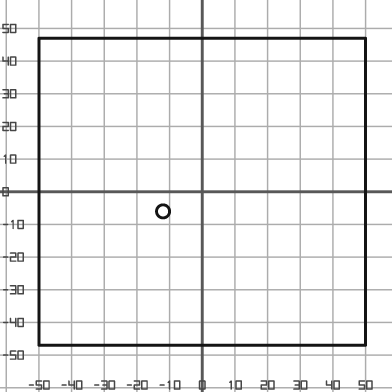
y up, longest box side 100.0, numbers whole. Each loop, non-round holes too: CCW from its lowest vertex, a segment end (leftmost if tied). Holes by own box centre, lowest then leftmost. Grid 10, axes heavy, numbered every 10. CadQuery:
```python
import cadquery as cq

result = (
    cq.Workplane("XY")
    .moveTo(-50.0, -47.0)
    .lineTo(50.0, -47.0)
    .lineTo(50.0, 47.0)
    .lineTo(-50.0, 47.0)
    .close()
    .moveTo(-12.0, -6.0)
    .circle(2.0)
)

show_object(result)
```